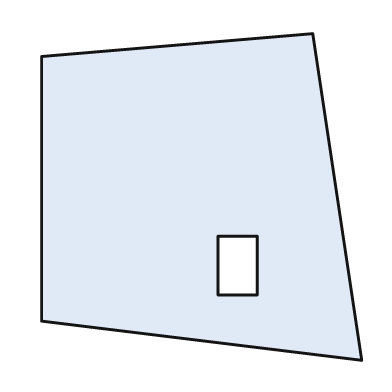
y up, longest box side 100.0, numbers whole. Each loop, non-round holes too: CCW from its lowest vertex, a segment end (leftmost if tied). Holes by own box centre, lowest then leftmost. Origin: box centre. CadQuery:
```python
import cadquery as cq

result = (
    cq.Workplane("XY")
    .moveTo(49.0, -50.0)
    .lineTo(34.0, 50.0)
    .lineTo(-49.0, 43.0)
    .lineTo(-49.0, -38.0)
    .close()
    .moveTo(5.0, -30.0)
    .lineTo(17.0, -30.0)
    .lineTo(17.0, -12.0)
    .lineTo(5.0, -12.0)
    .close()
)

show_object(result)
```